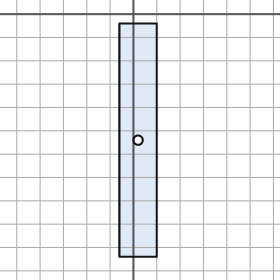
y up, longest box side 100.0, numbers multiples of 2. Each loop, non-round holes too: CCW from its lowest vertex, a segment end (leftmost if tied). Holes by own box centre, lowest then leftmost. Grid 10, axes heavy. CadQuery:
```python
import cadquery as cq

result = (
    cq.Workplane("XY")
    .moveTo(-6.0, -104.0)
    .lineTo(10.0, -104.0)
    .lineTo(10.0, -4.0)
    .lineTo(-6.0, -4.0)
    .close()
    .moveTo(2.0, -54.0)
    .circle(2.0)
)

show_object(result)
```